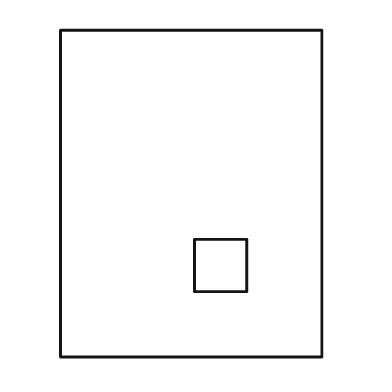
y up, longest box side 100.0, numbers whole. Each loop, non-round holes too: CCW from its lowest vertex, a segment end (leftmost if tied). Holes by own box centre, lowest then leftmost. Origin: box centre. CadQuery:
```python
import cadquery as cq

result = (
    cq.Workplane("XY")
    .moveTo(-40.0, -50.0)
    .lineTo(40.0, -50.0)
    .lineTo(40.0, 50.0)
    .lineTo(-40.0, 50.0)
    .close()
    .moveTo(1.0, -30.0)
    .lineTo(17.0, -30.0)
    .lineTo(17.0, -14.0)
    .lineTo(1.0, -14.0)
    .close()
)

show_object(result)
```